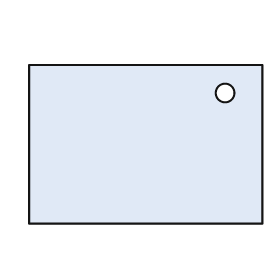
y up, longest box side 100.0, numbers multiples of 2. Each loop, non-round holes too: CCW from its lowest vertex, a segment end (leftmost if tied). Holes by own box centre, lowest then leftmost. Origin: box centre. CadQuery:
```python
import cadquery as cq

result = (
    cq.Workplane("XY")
    .moveTo(-50.0, -34.0)
    .lineTo(50.0, -34.0)
    .lineTo(50.0, 34.0)
    .lineTo(-50.0, 34.0)
    .close()
    .moveTo(34.0, 22.0)
    .circle(4.0)
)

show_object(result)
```